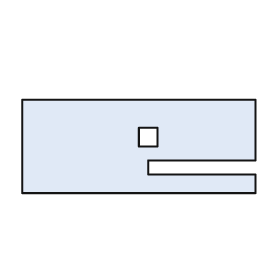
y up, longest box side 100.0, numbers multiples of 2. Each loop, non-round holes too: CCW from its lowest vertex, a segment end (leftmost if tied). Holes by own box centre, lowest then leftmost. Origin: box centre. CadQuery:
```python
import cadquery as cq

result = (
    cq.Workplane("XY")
    .moveTo(-50.0, -20.0)
    .lineTo(50.0, -20.0)
    .lineTo(50.0, -12.0)
    .lineTo(4.0, -12.0)
    .lineTo(4.0, -6.0)
    .lineTo(50.0, -6.0)
    .lineTo(50.0, 20.0)
    .lineTo(-50.0, 20.0)
    .close()
    .moveTo(0.0, 0.0)
    .lineTo(8.0, 0.0)
    .lineTo(8.0, 8.0)
    .lineTo(0.0, 8.0)
    .close()
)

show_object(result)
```